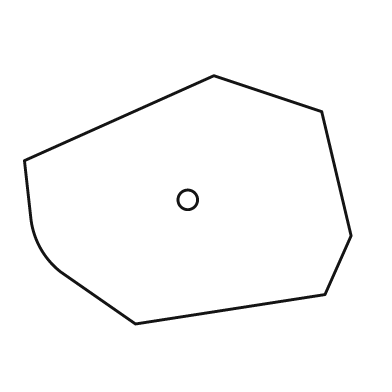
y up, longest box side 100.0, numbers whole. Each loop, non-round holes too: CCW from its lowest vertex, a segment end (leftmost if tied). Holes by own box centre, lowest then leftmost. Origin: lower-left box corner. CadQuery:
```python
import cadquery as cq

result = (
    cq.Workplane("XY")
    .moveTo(34.0, 0.0)
    .lineTo(92.0, 9.0)
    .lineTo(100.0, 27.0)
    .lineTo(91.0, 65.0)
    .lineTo(58.0, 76.0)
    .lineTo(0.0, 50.0)
    .lineTo(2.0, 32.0)
    .threePointArc((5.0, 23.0), (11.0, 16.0))
    .close()
    .moveTo(50.0, 38.0)
    .circle(3.0)
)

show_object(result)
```